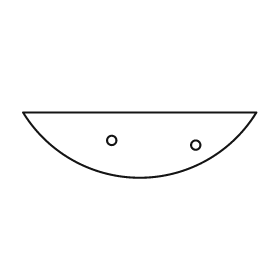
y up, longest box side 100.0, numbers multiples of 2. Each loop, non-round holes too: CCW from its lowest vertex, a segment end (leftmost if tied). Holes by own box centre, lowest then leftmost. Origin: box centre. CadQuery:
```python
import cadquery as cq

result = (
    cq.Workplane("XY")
    .moveTo(-50.0, 14.0)
    .threePointArc((0.0, -14.0), (50.0, 14.0))
    .close()
    .moveTo(24.0, 0.0)
    .circle(2.0)
    .moveTo(-12.0, 2.0)
    .circle(2.0)
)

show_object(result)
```